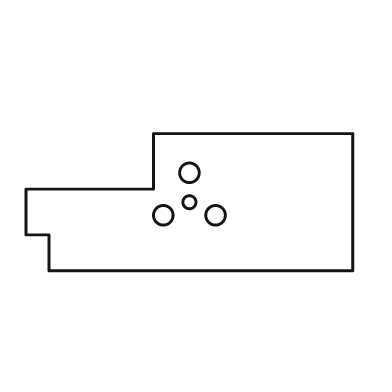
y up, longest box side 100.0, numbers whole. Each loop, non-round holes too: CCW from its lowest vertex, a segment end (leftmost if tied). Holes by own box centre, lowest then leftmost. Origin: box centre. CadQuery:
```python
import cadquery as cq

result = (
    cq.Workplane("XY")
    .moveTo(-43.0, -21.0)
    .lineTo(50.0, -21.0)
    .lineTo(50.0, 21.0)
    .lineTo(-11.0, 21.0)
    .lineTo(-11.0, 4.0)
    .lineTo(-50.0, 4.0)
    .lineTo(-50.0, -10.0)
    .lineTo(-43.0, -10.0)
    .close()
    .moveTo(-8.0, -4.0)
    .circle(3.0)
    .moveTo(8.0, -4.0)
    .circle(3.0)
    .moveTo(0.0, 0.0)
    .circle(2.0)
    .moveTo(0.0, 9.0)
    .circle(3.0)
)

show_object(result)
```